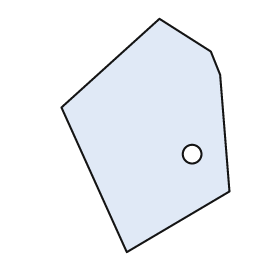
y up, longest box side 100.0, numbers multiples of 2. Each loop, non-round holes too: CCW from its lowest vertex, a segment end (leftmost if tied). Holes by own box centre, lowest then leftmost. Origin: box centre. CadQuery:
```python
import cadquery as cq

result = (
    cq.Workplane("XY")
    .moveTo(-8.0, -50.0)
    .lineTo(36.0, -24.0)
    .lineTo(32.0, 26.0)
    .lineTo(28.0, 36.0)
    .lineTo(6.0, 50.0)
    .lineTo(-36.0, 12.0)
    .close()
    .moveTo(20.0, -8.0)
    .circle(4.0)
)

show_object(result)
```